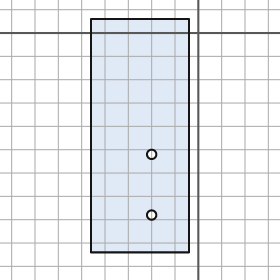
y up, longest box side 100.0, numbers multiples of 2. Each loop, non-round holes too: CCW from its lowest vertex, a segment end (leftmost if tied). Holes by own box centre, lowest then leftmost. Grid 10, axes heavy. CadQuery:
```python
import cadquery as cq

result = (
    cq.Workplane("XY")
    .moveTo(-46.0, -94.0)
    .lineTo(-4.0, -94.0)
    .lineTo(-4.0, 6.0)
    .lineTo(-46.0, 6.0)
    .close()
    .moveTo(-20.0, -78.0)
    .circle(2.0)
    .moveTo(-20.0, -52.0)
    .circle(2.0)
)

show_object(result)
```